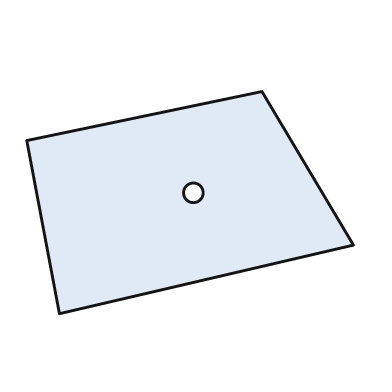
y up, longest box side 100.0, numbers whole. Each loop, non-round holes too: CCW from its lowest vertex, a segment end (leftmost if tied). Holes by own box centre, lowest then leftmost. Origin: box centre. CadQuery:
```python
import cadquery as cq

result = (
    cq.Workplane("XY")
    .moveTo(-40.0, -34.0)
    .lineTo(50.0, -13.0)
    .lineTo(22.0, 34.0)
    .lineTo(-50.0, 19.0)
    .close()
    .moveTo(1.0, 3.0)
    .circle(3.0)
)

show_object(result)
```